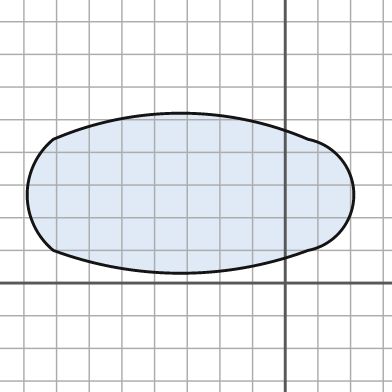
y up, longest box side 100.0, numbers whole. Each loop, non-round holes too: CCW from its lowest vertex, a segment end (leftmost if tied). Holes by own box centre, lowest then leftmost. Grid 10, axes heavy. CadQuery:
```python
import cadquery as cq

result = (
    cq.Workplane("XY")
    .moveTo(-71.0, 10.0)
    .threePointArc((-32.0, 3.0), (7.0, 10.0))
    .threePointArc((21.0, 27.0), (7.0, 44.0))
    .threePointArc((-32.0, 52.0), (-71.0, 44.0))
    .threePointArc((-79.0, 27.0), (-71.0, 10.0))
    .close()
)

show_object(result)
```